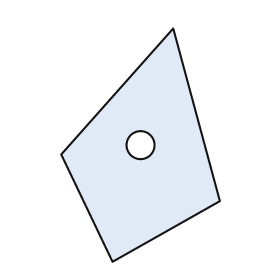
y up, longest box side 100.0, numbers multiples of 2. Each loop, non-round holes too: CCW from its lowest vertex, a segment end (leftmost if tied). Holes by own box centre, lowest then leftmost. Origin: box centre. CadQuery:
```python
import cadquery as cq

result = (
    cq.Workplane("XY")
    .moveTo(-12.0, -50.0)
    .lineTo(34.0, -24.0)
    .lineTo(14.0, 50.0)
    .lineTo(-34.0, -4.0)
    .close()
    .moveTo(0.0, 0.0)
    .circle(6.0)
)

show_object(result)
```